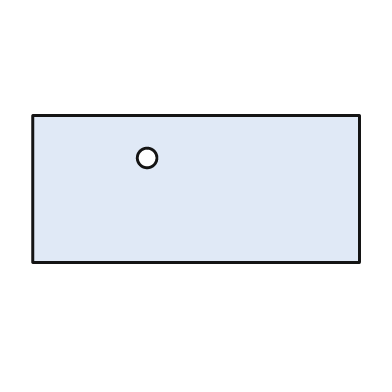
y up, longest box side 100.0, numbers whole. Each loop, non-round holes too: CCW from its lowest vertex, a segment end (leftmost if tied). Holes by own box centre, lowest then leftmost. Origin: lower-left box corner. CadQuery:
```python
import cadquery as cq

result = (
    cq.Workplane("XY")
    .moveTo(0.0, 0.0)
    .lineTo(100.0, 0.0)
    .lineTo(100.0, 45.0)
    .lineTo(0.0, 45.0)
    .close()
    .moveTo(35.0, 32.0)
    .circle(3.0)
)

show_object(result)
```